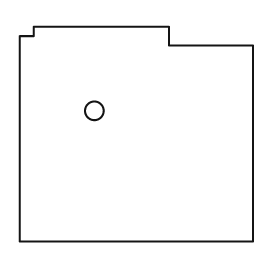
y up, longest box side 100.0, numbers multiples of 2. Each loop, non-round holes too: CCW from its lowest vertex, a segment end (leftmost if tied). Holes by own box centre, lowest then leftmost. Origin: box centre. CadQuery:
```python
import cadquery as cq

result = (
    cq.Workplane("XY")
    .moveTo(-50.0, -46.0)
    .lineTo(50.0, -46.0)
    .lineTo(50.0, 38.0)
    .lineTo(14.0, 38.0)
    .lineTo(14.0, 46.0)
    .lineTo(-44.0, 46.0)
    .lineTo(-44.0, 42.0)
    .lineTo(-50.0, 42.0)
    .close()
    .moveTo(-18.0, 10.0)
    .circle(4.0)
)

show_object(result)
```